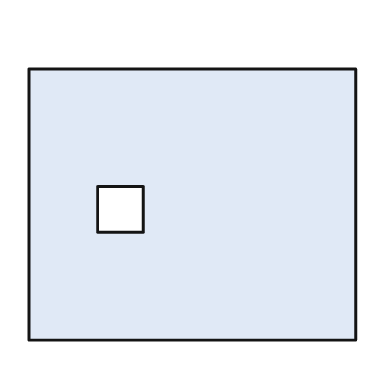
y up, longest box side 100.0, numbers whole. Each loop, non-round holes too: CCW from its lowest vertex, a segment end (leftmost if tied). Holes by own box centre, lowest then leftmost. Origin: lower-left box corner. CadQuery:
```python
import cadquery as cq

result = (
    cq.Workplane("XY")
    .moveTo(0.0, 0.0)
    .lineTo(100.0, 0.0)
    .lineTo(100.0, 83.0)
    .lineTo(0.0, 83.0)
    .close()
    .moveTo(21.0, 33.0)
    .lineTo(35.0, 33.0)
    .lineTo(35.0, 47.0)
    .lineTo(21.0, 47.0)
    .close()
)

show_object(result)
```